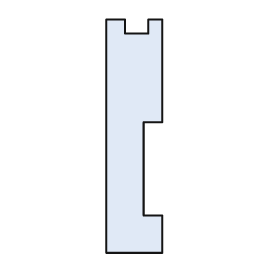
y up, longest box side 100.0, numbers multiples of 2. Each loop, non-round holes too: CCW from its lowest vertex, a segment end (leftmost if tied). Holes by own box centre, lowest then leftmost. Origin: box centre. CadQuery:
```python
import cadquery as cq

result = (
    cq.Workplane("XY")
    .moveTo(-12.0, -50.0)
    .lineTo(12.0, -50.0)
    .lineTo(12.0, -34.0)
    .lineTo(4.0, -34.0)
    .lineTo(4.0, 6.0)
    .lineTo(12.0, 6.0)
    .lineTo(12.0, 50.0)
    .lineTo(6.0, 50.0)
    .lineTo(6.0, 44.0)
    .lineTo(-4.0, 44.0)
    .lineTo(-4.0, 50.0)
    .lineTo(-12.0, 50.0)
    .close()
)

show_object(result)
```